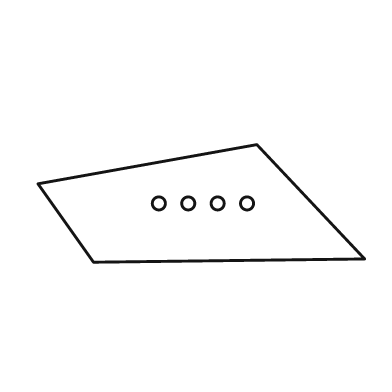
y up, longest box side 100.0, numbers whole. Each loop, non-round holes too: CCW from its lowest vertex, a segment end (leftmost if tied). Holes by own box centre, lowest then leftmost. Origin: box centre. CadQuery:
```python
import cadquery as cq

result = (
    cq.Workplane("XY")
    .moveTo(-33.0, -18.0)
    .lineTo(50.0, -17.0)
    .lineTo(17.0, 18.0)
    .lineTo(-50.0, 6.0)
    .close()
    .moveTo(-13.0, 0.0)
    .circle(2.0)
    .moveTo(-4.0, 0.0)
    .circle(2.0)
    .moveTo(5.0, 0.0)
    .circle(2.0)
    .moveTo(14.0, 0.0)
    .circle(2.0)
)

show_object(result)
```